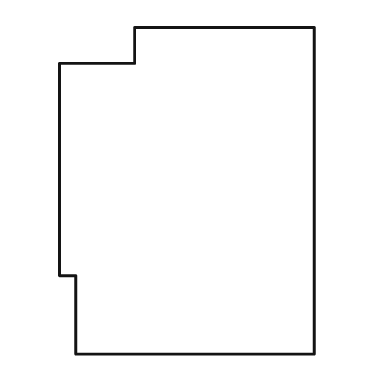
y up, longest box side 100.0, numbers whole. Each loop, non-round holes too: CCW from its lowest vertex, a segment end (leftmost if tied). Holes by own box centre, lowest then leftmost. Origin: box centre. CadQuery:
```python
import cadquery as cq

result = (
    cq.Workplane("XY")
    .moveTo(-34.0, -50.0)
    .lineTo(39.0, -50.0)
    .lineTo(39.0, 50.0)
    .lineTo(-16.0, 50.0)
    .lineTo(-16.0, 39.0)
    .lineTo(-39.0, 39.0)
    .lineTo(-39.0, -26.0)
    .lineTo(-34.0, -26.0)
    .close()
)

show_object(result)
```